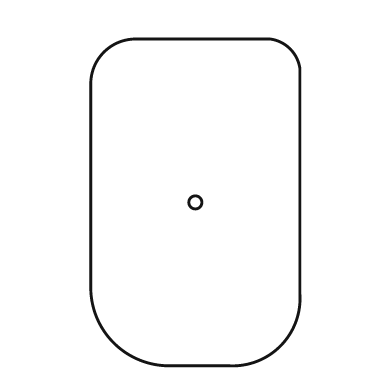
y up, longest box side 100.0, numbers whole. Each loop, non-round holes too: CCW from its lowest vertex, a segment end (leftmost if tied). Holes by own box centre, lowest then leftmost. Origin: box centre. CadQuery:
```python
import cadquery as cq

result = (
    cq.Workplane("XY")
    .moveTo(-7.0, -50.0)
    .lineTo(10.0, -50.0)
    .threePointArc((26.0, -44.0), (32.0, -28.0))
    .lineTo(32.0, 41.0)
    .threePointArc((29.0, 47.0), (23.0, 50.0))
    .lineTo(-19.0, 50.0)
    .threePointArc((-28.0, 46.0), (-32.0, 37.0))
    .lineTo(-32.0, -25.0)
    .threePointArc((-25.0, -43.0), (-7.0, -50.0))
    .close()
    .moveTo(0.0, 0.0)
    .circle(2.0)
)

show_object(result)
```